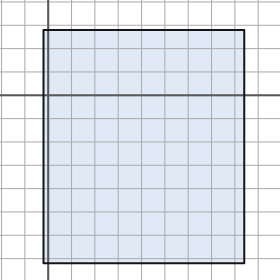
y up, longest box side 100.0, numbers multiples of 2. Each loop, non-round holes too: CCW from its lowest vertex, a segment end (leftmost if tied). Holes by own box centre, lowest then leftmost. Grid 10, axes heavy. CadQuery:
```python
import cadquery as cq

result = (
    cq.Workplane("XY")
    .moveTo(-2.0, -72.0)
    .lineTo(84.0, -72.0)
    .lineTo(84.0, 28.0)
    .lineTo(-2.0, 28.0)
    .close()
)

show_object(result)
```